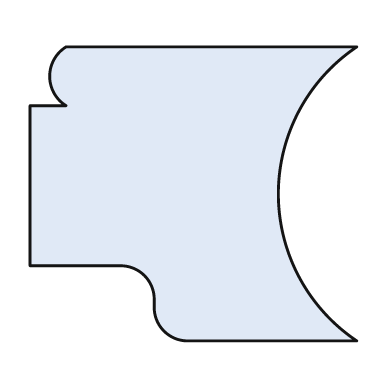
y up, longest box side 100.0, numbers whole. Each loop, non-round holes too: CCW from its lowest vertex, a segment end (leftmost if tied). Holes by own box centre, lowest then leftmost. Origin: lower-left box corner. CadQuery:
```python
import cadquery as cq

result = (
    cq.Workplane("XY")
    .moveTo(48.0, 0.0)
    .lineTo(100.0, 0.0)
    .threePointArc((76.0, 45.0), (100.0, 90.0))
    .lineTo(11.0, 90.0)
    .threePointArc((6.0, 81.0), (11.0, 72.0))
    .lineTo(0.0, 72.0)
    .lineTo(0.0, 23.0)
    .lineTo(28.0, 23.0)
    .threePointArc((35.0, 20.0), (38.0, 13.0))
    .lineTo(38.0, 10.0)
    .threePointArc((41.0, 3.0), (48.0, 0.0))
    .close()
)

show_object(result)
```